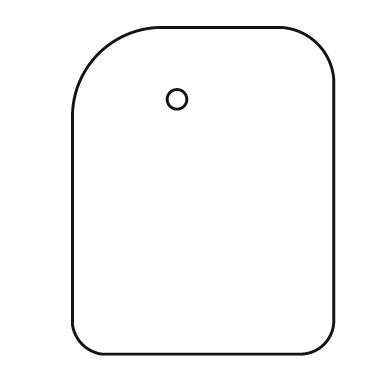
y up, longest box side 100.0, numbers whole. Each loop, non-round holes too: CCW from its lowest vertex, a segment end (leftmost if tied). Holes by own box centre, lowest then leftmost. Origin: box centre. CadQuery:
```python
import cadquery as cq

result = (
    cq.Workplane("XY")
    .moveTo(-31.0, -50.0)
    .lineTo(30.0, -50.0)
    .threePointArc((37.0, -47.0), (40.0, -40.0))
    .lineTo(40.0, 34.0)
    .threePointArc((35.0, 45.0), (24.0, 50.0))
    .lineTo(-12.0, 50.0)
    .threePointArc((-32.0, 42.0), (-40.0, 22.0))
    .lineTo(-40.0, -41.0)
    .threePointArc((-37.0, -47.0), (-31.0, -50.0))
    .close()
    .moveTo(-8.0, 28.0)
    .circle(3.0)
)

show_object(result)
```